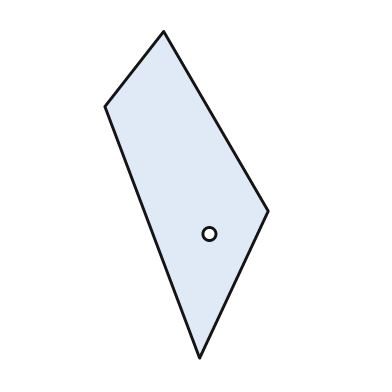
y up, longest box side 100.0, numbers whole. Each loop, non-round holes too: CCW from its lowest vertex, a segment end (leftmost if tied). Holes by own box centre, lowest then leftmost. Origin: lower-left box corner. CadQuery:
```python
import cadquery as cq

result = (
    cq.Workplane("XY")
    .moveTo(29.0, 0.0)
    .lineTo(50.0, 45.0)
    .lineTo(18.0, 100.0)
    .lineTo(0.0, 77.0)
    .close()
    .moveTo(32.0, 38.0)
    .circle(2.0)
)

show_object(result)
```